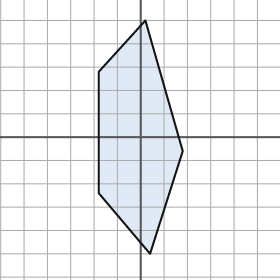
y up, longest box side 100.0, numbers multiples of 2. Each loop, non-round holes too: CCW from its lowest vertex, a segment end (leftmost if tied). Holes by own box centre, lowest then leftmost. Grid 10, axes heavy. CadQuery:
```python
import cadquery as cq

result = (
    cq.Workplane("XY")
    .moveTo(4.0, -50.0)
    .lineTo(18.0, -6.0)
    .lineTo(2.0, 50.0)
    .lineTo(-18.0, 28.0)
    .lineTo(-18.0, -24.0)
    .close()
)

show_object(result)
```